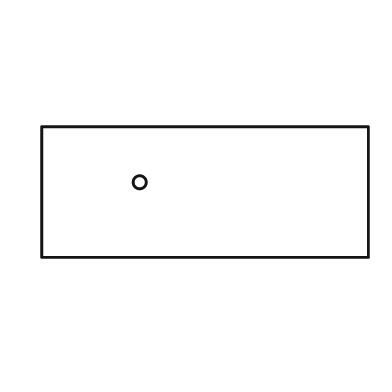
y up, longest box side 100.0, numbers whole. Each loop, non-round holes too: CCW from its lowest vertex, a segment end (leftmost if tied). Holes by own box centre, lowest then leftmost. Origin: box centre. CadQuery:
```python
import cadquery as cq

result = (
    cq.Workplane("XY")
    .moveTo(-50.0, -20.0)
    .lineTo(50.0, -20.0)
    .lineTo(50.0, 20.0)
    .lineTo(-50.0, 20.0)
    .close()
    .moveTo(-20.0, 3.0)
    .circle(2.0)
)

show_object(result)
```